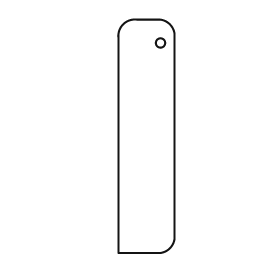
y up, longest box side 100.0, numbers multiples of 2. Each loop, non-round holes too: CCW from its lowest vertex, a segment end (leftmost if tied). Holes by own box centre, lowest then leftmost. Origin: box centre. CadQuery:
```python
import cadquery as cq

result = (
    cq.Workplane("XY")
    .moveTo(-12.0, -50.0)
    .lineTo(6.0, -50.0)
    .threePointArc((10.0, -48.0), (12.0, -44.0))
    .lineTo(12.0, 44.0)
    .threePointArc((10.0, 48.0), (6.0, 50.0))
    .lineTo(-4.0, 50.0)
    .threePointArc((-10.0, 48.0), (-12.0, 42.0))
    .close()
    .moveTo(6.0, 40.0)
    .circle(2.0)
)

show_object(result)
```